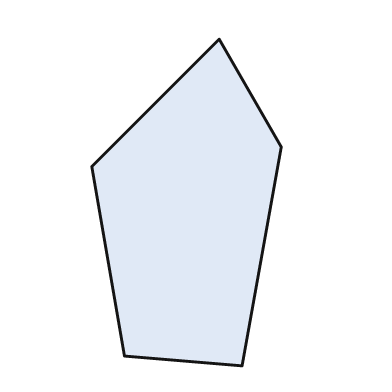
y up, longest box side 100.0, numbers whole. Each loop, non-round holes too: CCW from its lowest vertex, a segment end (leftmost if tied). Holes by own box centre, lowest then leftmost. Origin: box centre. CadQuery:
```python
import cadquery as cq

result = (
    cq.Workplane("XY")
    .moveTo(17.0, -50.0)
    .lineTo(29.0, 17.0)
    .lineTo(10.0, 50.0)
    .lineTo(-29.0, 11.0)
    .lineTo(-19.0, -47.0)
    .close()
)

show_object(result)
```